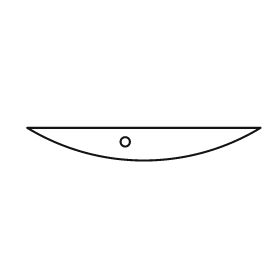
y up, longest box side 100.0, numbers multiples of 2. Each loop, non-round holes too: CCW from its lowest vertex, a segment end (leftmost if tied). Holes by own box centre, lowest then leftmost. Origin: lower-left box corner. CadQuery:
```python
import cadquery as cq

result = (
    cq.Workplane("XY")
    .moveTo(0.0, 14.0)
    .threePointArc((50.0, 0.0), (100.0, 14.0))
    .close()
    .moveTo(42.0, 8.0)
    .circle(2.0)
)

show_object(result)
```